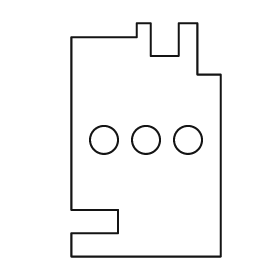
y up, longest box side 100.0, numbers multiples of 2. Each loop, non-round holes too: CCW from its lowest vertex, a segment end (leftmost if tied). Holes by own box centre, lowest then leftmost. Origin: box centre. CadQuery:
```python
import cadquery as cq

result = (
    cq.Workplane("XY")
    .moveTo(-32.0, -50.0)
    .lineTo(32.0, -50.0)
    .lineTo(32.0, 28.0)
    .lineTo(22.0, 28.0)
    .lineTo(22.0, 50.0)
    .lineTo(14.0, 50.0)
    .lineTo(14.0, 36.0)
    .lineTo(2.0, 36.0)
    .lineTo(2.0, 50.0)
    .lineTo(-4.0, 50.0)
    .lineTo(-4.0, 44.0)
    .lineTo(-32.0, 44.0)
    .lineTo(-32.0, -30.0)
    .lineTo(-12.0, -30.0)
    .lineTo(-12.0, -40.0)
    .lineTo(-32.0, -40.0)
    .close()
    .moveTo(-18.0, 0.0)
    .circle(6.0)
    .moveTo(0.0, 0.0)
    .circle(6.0)
    .moveTo(18.0, 0.0)
    .circle(6.0)
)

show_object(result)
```